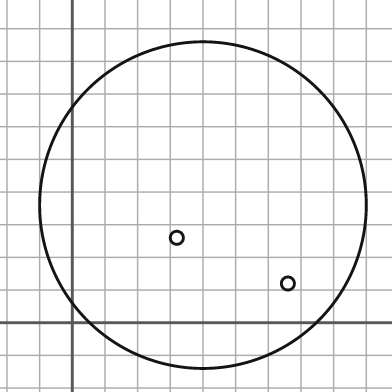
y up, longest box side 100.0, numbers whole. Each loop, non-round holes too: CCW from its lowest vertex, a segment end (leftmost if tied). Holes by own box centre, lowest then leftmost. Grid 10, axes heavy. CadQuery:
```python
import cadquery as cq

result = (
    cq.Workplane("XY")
    .moveTo(40.0, 36.0)
    .circle(50.0)
    .moveTo(66.0, 12.0)
    .circle(2.0)
    .moveTo(32.0, 26.0)
    .circle(2.0)
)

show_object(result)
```